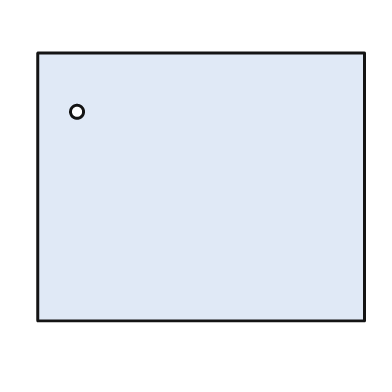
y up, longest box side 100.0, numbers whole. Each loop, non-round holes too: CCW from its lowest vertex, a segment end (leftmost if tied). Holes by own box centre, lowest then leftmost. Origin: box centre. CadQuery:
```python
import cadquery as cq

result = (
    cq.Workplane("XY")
    .moveTo(-50.0, -41.0)
    .lineTo(50.0, -41.0)
    .lineTo(50.0, 41.0)
    .lineTo(-50.0, 41.0)
    .close()
    .moveTo(-38.0, 23.0)
    .circle(2.0)
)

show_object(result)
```